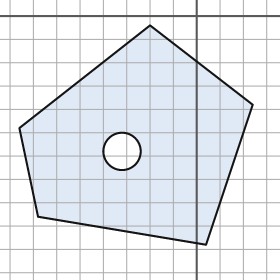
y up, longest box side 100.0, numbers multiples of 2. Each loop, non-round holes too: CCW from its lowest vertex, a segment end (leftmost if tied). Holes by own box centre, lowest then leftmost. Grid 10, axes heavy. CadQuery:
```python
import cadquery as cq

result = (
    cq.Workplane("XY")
    .moveTo(4.0, -98.0)
    .lineTo(24.0, -38.0)
    .lineTo(-20.0, -4.0)
    .lineTo(-76.0, -48.0)
    .lineTo(-68.0, -86.0)
    .close()
    .moveTo(-32.0, -58.0)
    .circle(8.0)
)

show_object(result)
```